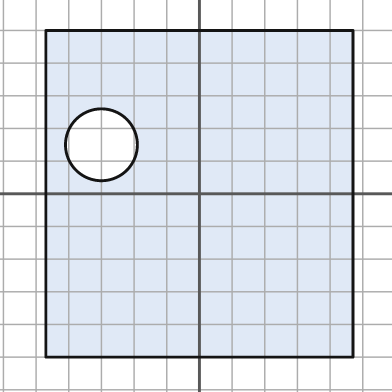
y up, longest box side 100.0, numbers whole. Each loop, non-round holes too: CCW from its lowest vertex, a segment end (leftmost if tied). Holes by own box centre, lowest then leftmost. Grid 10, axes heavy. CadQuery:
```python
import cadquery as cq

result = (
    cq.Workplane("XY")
    .moveTo(-47.0, -50.0)
    .lineTo(47.0, -50.0)
    .lineTo(47.0, 50.0)
    .lineTo(-47.0, 50.0)
    .close()
    .moveTo(-30.0, 15.0)
    .circle(11.0)
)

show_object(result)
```